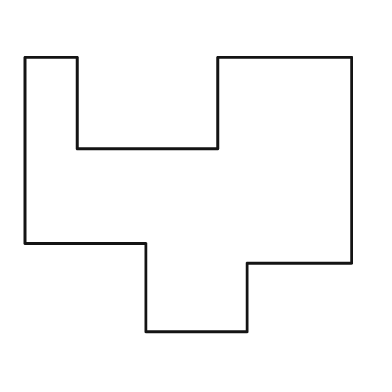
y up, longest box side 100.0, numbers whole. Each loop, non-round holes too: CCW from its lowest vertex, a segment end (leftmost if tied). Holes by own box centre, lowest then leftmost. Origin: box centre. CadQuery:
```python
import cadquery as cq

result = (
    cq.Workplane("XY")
    .moveTo(-13.0, -42.0)
    .lineTo(18.0, -42.0)
    .lineTo(18.0, -21.0)
    .lineTo(50.0, -21.0)
    .lineTo(50.0, 42.0)
    .lineTo(9.0, 42.0)
    .lineTo(9.0, 14.0)
    .lineTo(-34.0, 14.0)
    .lineTo(-34.0, 42.0)
    .lineTo(-50.0, 42.0)
    .lineTo(-50.0, -15.0)
    .lineTo(-13.0, -15.0)
    .close()
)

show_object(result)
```